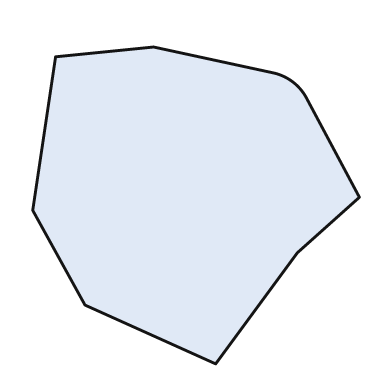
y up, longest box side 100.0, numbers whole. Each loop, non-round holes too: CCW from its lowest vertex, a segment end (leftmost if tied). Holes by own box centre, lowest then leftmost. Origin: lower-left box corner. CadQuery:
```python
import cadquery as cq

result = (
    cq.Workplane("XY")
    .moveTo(56.0, 0.0)
    .lineTo(81.0, 34.0)
    .lineTo(100.0, 51.0)
    .lineTo(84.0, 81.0)
    .threePointArc((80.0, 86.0), (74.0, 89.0))
    .lineTo(37.0, 97.0)
    .lineTo(7.0, 94.0)
    .lineTo(0.0, 47.0)
    .lineTo(16.0, 18.0)
    .close()
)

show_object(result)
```